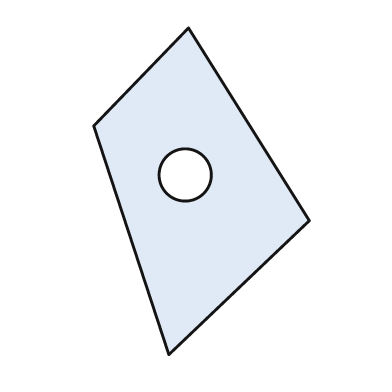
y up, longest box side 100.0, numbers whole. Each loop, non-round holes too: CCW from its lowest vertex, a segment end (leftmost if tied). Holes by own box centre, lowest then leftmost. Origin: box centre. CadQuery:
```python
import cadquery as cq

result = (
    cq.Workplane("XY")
    .moveTo(-10.0, -50.0)
    .lineTo(33.0, -9.0)
    .lineTo(-4.0, 50.0)
    .lineTo(-33.0, 20.0)
    .close()
    .moveTo(-5.0, 5.0)
    .circle(8.0)
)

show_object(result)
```